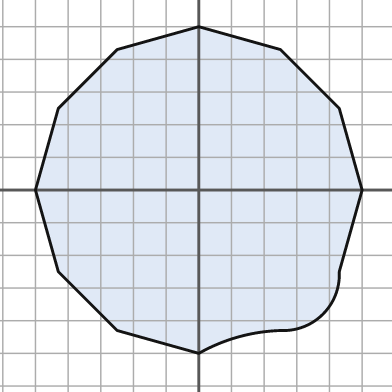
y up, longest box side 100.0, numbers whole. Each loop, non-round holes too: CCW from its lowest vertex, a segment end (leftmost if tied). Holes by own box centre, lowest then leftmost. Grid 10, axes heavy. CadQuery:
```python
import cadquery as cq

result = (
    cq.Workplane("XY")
    .moveTo(0.0, -50.0)
    .threePointArc((12.0, -45.0), (25.0, -43.0))
    .threePointArc((38.0, -38.0), (43.0, -25.0))
    .lineTo(50.0, 0.0)
    .lineTo(43.0, 25.0)
    .lineTo(25.0, 43.0)
    .lineTo(0.0, 50.0)
    .lineTo(-25.0, 43.0)
    .lineTo(-43.0, 25.0)
    .lineTo(-50.0, 0.0)
    .lineTo(-43.0, -25.0)
    .lineTo(-25.0, -43.0)
    .close()
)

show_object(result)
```